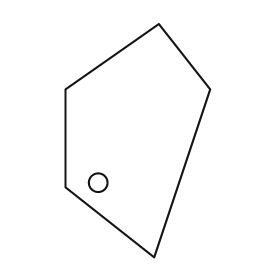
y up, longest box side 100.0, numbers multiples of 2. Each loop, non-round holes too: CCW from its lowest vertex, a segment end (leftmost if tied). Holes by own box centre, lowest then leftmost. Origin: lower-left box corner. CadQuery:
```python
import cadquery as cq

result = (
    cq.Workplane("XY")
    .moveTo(38.0, 0.0)
    .lineTo(62.0, 72.0)
    .lineTo(40.0, 100.0)
    .lineTo(0.0, 72.0)
    .lineTo(0.0, 30.0)
    .close()
    .moveTo(14.0, 32.0)
    .circle(4.0)
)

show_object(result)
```